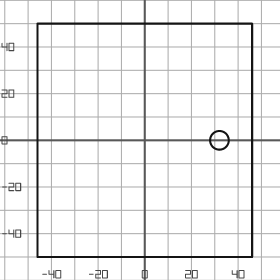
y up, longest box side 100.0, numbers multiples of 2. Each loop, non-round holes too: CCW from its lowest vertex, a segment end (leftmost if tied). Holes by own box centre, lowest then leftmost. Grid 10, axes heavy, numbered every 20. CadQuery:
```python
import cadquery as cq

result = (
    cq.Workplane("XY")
    .moveTo(-46.0, -50.0)
    .lineTo(46.0, -50.0)
    .lineTo(46.0, 50.0)
    .lineTo(-46.0, 50.0)
    .close()
    .moveTo(32.0, 0.0)
    .circle(4.0)
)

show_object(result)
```